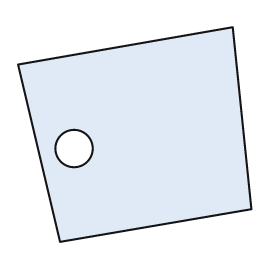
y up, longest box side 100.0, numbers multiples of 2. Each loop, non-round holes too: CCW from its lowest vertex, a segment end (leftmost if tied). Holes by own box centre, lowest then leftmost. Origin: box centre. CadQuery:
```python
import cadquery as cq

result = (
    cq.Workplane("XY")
    .moveTo(-32.0, -46.0)
    .lineTo(50.0, -32.0)
    .lineTo(42.0, 46.0)
    .lineTo(-50.0, 30.0)
    .close()
    .moveTo(-26.0, -6.0)
    .circle(8.0)
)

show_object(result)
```